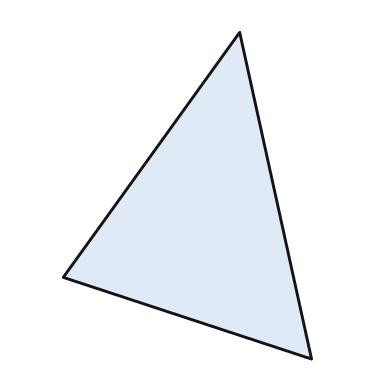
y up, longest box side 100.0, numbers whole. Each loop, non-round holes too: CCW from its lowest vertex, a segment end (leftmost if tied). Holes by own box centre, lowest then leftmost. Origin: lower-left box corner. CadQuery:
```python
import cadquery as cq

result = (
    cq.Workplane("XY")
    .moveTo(76.0, 0.0)
    .lineTo(54.0, 100.0)
    .lineTo(0.0, 25.0)
    .close()
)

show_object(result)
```